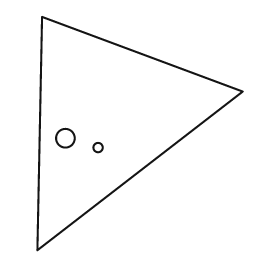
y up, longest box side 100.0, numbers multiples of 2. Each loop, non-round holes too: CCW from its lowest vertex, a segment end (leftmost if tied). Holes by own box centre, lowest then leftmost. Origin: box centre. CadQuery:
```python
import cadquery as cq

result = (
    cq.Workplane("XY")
    .moveTo(-44.0, -50.0)
    .lineTo(44.0, 18.0)
    .lineTo(-42.0, 50.0)
    .close()
    .moveTo(-18.0, -6.0)
    .circle(2.0)
    .moveTo(-32.0, -2.0)
    .circle(4.0)
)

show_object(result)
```